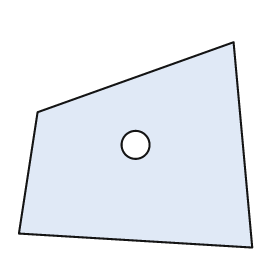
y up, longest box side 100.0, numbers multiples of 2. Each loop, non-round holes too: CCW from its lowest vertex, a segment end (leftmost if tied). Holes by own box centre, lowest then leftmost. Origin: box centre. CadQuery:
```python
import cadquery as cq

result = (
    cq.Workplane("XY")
    .moveTo(50.0, -44.0)
    .lineTo(42.0, 44.0)
    .lineTo(-42.0, 14.0)
    .lineTo(-50.0, -38.0)
    .close()
    .moveTo(0.0, 0.0)
    .circle(6.0)
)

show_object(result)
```